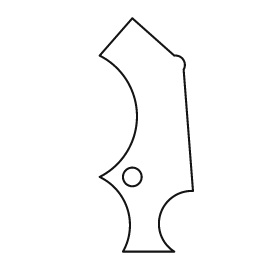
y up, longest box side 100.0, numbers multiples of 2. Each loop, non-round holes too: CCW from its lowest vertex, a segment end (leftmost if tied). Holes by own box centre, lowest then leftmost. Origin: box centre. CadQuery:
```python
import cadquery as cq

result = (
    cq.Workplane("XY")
    .moveTo(-10.0, -50.0)
    .lineTo(12.0, -50.0)
    .threePointArc((6.0, -34.0), (20.0, -24.0))
    .lineTo(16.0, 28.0)
    .threePointArc((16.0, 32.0), (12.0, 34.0))
    .lineTo(-6.0, 50.0)
    .lineTo(-20.0, 34.0)
    .threePointArc((-4.0, 8.0), (-20.0, -18.0))
    .threePointArc((-8.0, -32.0), (-10.0, -50.0))
    .close()
    .moveTo(-6.0, -18.0)
    .circle(4.0)
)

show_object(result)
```